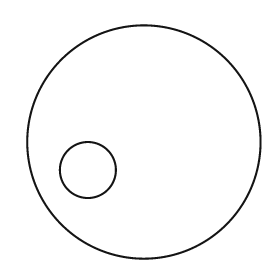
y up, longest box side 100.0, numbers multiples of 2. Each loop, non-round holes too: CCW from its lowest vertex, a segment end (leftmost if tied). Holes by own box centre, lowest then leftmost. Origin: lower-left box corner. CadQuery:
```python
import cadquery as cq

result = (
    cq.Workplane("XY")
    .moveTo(50.0, 50.0)
    .circle(50.0)
    .moveTo(26.0, 38.0)
    .circle(12.0)
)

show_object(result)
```